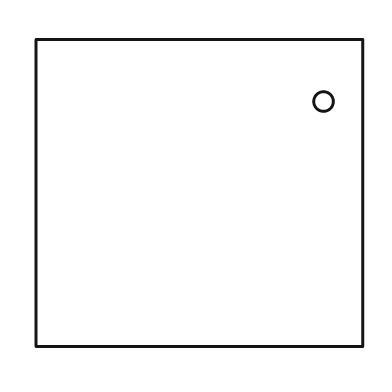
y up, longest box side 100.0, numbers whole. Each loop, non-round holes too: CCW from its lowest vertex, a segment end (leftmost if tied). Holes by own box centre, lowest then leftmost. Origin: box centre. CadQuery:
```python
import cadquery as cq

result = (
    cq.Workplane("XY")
    .moveTo(-50.0, -47.0)
    .lineTo(50.0, -47.0)
    .lineTo(50.0, 47.0)
    .lineTo(-50.0, 47.0)
    .close()
    .moveTo(38.0, 28.0)
    .circle(3.0)
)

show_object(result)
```